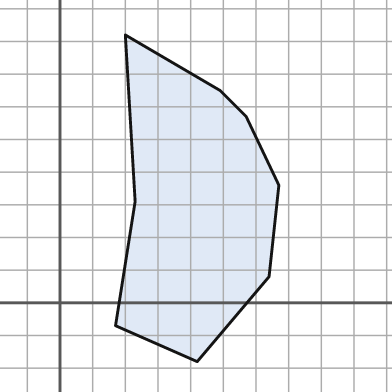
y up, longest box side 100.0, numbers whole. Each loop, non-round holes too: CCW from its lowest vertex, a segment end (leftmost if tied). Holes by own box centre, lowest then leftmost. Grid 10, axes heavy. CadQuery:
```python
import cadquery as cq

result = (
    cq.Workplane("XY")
    .moveTo(42.0, -18.0)
    .lineTo(64.0, 8.0)
    .lineTo(67.0, 36.0)
    .lineTo(57.0, 57.0)
    .lineTo(49.0, 65.0)
    .lineTo(20.0, 82.0)
    .lineTo(23.0, 31.0)
    .lineTo(17.0, -7.0)
    .close()
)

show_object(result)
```